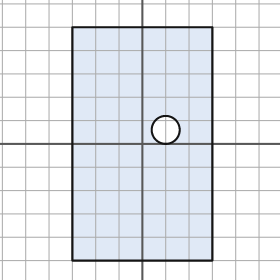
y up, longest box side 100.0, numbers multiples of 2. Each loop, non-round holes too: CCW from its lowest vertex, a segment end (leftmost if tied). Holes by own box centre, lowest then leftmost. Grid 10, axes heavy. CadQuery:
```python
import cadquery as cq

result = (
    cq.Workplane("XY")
    .moveTo(-30.0, -50.0)
    .lineTo(30.0, -50.0)
    .lineTo(30.0, 50.0)
    .lineTo(-30.0, 50.0)
    .close()
    .moveTo(10.0, 6.0)
    .circle(6.0)
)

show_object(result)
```